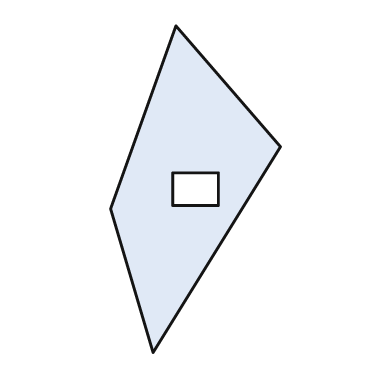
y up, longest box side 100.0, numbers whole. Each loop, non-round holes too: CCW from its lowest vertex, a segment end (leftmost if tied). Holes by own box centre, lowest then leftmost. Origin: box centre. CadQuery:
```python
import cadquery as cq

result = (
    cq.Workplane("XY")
    .moveTo(-13.0, -50.0)
    .lineTo(26.0, 13.0)
    .lineTo(-6.0, 50.0)
    .lineTo(-26.0, -6.0)
    .close()
    .moveTo(-7.0, -5.0)
    .lineTo(7.0, -5.0)
    .lineTo(7.0, 5.0)
    .lineTo(-7.0, 5.0)
    .close()
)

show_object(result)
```